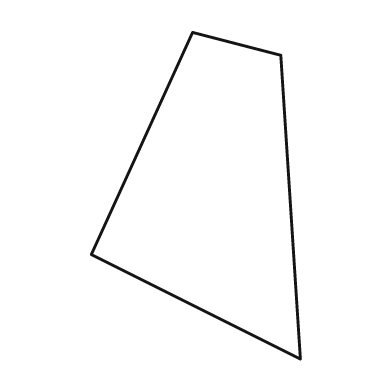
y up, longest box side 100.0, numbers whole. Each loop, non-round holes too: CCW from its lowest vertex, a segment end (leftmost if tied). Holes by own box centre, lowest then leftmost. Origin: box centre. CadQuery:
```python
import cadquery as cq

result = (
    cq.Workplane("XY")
    .moveTo(32.0, -50.0)
    .lineTo(26.0, 43.0)
    .lineTo(-1.0, 50.0)
    .lineTo(-32.0, -18.0)
    .close()
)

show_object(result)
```